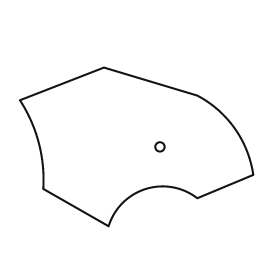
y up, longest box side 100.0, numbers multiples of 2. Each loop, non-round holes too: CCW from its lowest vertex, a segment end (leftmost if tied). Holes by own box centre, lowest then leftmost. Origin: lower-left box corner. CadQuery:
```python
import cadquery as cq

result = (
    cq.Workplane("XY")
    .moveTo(38.0, 0.0)
    .threePointArc((54.0, 16.0), (76.0, 12.0))
    .lineTo(100.0, 22.0)
    .threePointArc((92.0, 42.0), (76.0, 56.0))
    .lineTo(36.0, 68.0)
    .lineTo(0.0, 54.0)
    .threePointArc((8.0, 36.0), (10.0, 16.0))
    .close()
    .moveTo(60.0, 34.0)
    .circle(2.0)
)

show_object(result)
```